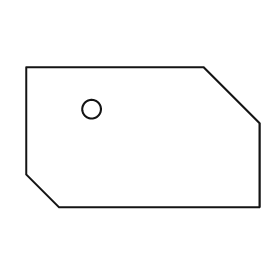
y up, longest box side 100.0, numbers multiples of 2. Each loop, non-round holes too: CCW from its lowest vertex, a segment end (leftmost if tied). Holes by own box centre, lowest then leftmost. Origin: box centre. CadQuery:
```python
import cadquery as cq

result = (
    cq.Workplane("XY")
    .moveTo(-36.0, -30.0)
    .lineTo(50.0, -30.0)
    .lineTo(50.0, 6.0)
    .lineTo(26.0, 30.0)
    .lineTo(-50.0, 30.0)
    .lineTo(-50.0, -16.0)
    .close()
    .moveTo(-22.0, 12.0)
    .circle(4.0)
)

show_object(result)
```